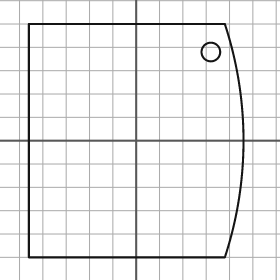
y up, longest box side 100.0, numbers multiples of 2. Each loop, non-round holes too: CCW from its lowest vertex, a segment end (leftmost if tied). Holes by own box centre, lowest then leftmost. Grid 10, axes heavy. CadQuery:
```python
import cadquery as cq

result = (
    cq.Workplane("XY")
    .moveTo(-46.0, -50.0)
    .lineTo(38.0, -50.0)
    .threePointArc((46.0, 0.0), (38.0, 50.0))
    .lineTo(-46.0, 50.0)
    .close()
    .moveTo(32.0, 38.0)
    .circle(4.0)
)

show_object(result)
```